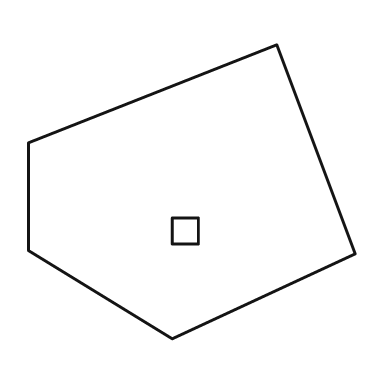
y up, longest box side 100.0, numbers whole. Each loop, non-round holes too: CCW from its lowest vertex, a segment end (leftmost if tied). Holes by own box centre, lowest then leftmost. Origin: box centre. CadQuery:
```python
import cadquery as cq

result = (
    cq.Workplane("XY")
    .moveTo(-6.0, -45.0)
    .lineTo(50.0, -19.0)
    .lineTo(26.0, 45.0)
    .lineTo(-50.0, 15.0)
    .lineTo(-50.0, -18.0)
    .close()
    .moveTo(-6.0, -16.0)
    .lineTo(2.0, -16.0)
    .lineTo(2.0, -8.0)
    .lineTo(-6.0, -8.0)
    .close()
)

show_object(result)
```